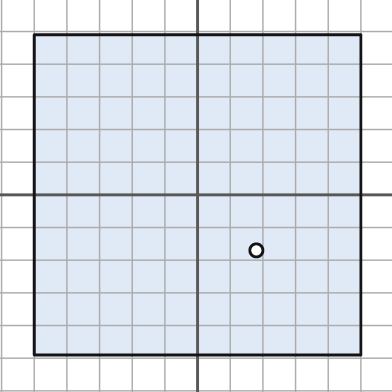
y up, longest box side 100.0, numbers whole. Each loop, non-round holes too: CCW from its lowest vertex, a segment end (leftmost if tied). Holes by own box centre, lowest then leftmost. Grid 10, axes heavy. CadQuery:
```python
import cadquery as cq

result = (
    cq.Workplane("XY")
    .moveTo(-50.0, -49.0)
    .lineTo(50.0, -49.0)
    .lineTo(50.0, 49.0)
    .lineTo(-50.0, 49.0)
    .close()
    .moveTo(18.0, -17.0)
    .circle(2.0)
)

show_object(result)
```